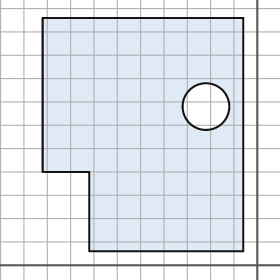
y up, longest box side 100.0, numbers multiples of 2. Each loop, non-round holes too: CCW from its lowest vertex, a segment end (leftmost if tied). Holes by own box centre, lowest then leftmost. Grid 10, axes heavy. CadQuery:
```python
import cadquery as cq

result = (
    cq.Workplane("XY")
    .moveTo(-72.0, 6.0)
    .lineTo(-6.0, 6.0)
    .lineTo(-6.0, 106.0)
    .lineTo(-92.0, 106.0)
    .lineTo(-92.0, 40.0)
    .lineTo(-72.0, 40.0)
    .close()
    .moveTo(-22.0, 68.0)
    .circle(10.0)
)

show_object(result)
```